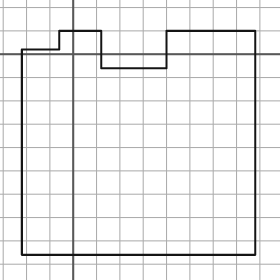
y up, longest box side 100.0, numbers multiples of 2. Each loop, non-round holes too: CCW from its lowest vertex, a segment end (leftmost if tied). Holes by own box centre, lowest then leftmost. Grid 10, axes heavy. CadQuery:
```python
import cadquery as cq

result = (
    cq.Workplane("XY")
    .moveTo(-22.0, -86.0)
    .lineTo(78.0, -86.0)
    .lineTo(78.0, 10.0)
    .lineTo(40.0, 10.0)
    .lineTo(40.0, -6.0)
    .lineTo(12.0, -6.0)
    .lineTo(12.0, 10.0)
    .lineTo(-6.0, 10.0)
    .lineTo(-6.0, 2.0)
    .lineTo(-22.0, 2.0)
    .close()
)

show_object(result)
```